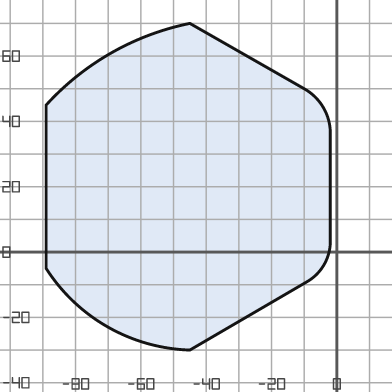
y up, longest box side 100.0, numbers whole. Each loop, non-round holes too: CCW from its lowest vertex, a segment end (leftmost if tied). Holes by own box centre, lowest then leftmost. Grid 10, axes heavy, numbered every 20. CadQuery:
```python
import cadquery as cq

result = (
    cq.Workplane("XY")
    .moveTo(-45.0, -30.0)
    .lineTo(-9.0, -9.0)
    .threePointArc((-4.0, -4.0), (-2.0, 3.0))
    .lineTo(-2.0, 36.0)
    .threePointArc((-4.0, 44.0), (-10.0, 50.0))
    .lineTo(-45.0, 70.0)
    .threePointArc((-69.0, 61.0), (-89.0, 45.0))
    .lineTo(-89.0, -5.0)
    .threePointArc((-70.0, -23.0), (-45.0, -30.0))
    .close()
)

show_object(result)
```